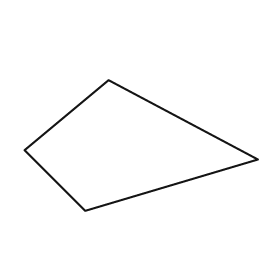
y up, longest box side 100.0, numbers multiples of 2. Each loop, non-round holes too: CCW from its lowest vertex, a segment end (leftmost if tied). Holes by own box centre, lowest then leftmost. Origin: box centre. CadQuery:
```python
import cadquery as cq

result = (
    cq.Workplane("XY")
    .moveTo(-24.0, -28.0)
    .lineTo(50.0, -6.0)
    .lineTo(-14.0, 28.0)
    .lineTo(-50.0, -2.0)
    .close()
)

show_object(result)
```